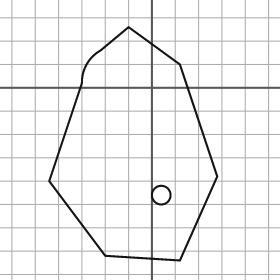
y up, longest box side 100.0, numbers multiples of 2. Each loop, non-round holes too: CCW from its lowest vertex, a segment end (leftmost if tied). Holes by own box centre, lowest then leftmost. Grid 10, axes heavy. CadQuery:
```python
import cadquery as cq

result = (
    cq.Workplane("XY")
    .moveTo(12.0, -74.0)
    .lineTo(28.0, -38.0)
    .lineTo(12.0, 10.0)
    .lineTo(-10.0, 26.0)
    .lineTo(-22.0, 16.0)
    .threePointArc((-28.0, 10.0), (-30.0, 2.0))
    .lineTo(-44.0, -40.0)
    .lineTo(-20.0, -72.0)
    .close()
    .moveTo(4.0, -46.0)
    .circle(4.0)
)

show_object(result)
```